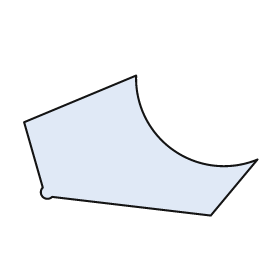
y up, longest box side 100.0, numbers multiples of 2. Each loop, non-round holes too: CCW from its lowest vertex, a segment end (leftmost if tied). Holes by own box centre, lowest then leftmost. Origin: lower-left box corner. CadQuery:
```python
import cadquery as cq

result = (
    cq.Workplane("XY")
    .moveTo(80.0, 0.0)
    .lineTo(100.0, 24.0)
    .threePointArc((64.0, 28.0), (48.0, 60.0))
    .lineTo(0.0, 40.0)
    .lineTo(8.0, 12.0)
    .threePointArc((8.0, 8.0), (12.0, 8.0))
    .close()
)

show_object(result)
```